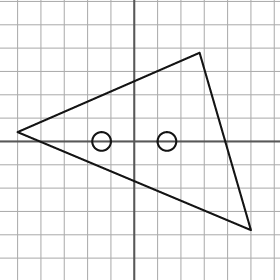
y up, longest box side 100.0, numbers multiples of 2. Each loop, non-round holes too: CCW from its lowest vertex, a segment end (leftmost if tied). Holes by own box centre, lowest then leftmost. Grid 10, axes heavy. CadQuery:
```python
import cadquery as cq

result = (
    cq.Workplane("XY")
    .moveTo(50.0, -38.0)
    .lineTo(28.0, 38.0)
    .lineTo(-50.0, 4.0)
    .close()
    .moveTo(-14.0, 0.0)
    .circle(4.0)
    .moveTo(14.0, 0.0)
    .circle(4.0)
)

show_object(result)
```